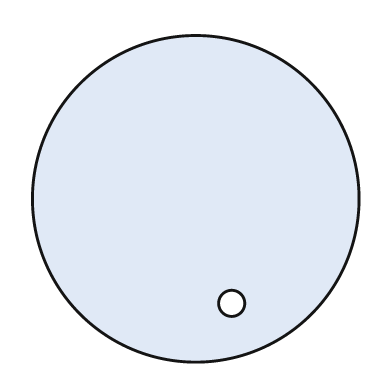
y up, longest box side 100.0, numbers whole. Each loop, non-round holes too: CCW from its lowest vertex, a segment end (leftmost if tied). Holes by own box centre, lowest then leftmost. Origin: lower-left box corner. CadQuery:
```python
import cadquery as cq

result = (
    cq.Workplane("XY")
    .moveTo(50.0, 50.0)
    .circle(50.0)
    .moveTo(61.0, 18.0)
    .circle(4.0)
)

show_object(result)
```